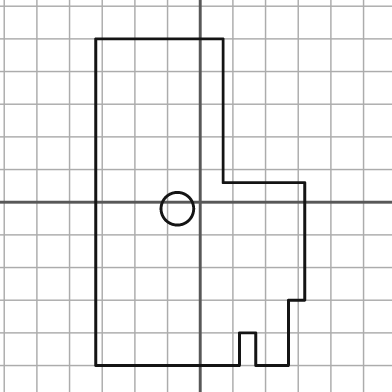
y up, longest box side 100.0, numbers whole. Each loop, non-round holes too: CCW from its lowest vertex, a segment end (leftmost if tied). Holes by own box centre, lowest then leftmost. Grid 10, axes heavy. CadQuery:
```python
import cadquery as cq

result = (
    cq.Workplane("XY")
    .moveTo(-32.0, -50.0)
    .lineTo(12.0, -50.0)
    .lineTo(12.0, -40.0)
    .lineTo(17.0, -40.0)
    .lineTo(17.0, -50.0)
    .lineTo(27.0, -50.0)
    .lineTo(27.0, -30.0)
    .lineTo(32.0, -30.0)
    .lineTo(32.0, 6.0)
    .lineTo(7.0, 6.0)
    .lineTo(7.0, 50.0)
    .lineTo(-32.0, 50.0)
    .close()
    .moveTo(-7.0, -2.0)
    .circle(5.0)
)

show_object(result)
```